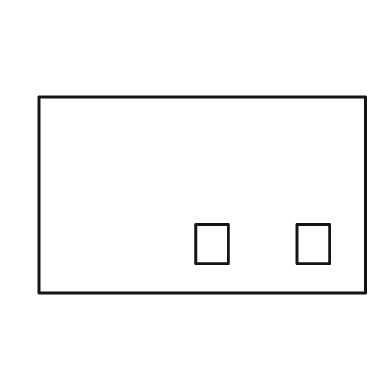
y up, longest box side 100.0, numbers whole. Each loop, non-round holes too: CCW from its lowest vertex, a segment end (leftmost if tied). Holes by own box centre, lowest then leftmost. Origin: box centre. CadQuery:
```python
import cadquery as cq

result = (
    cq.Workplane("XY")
    .moveTo(-50.0, -30.0)
    .lineTo(50.0, -30.0)
    .lineTo(50.0, 30.0)
    .lineTo(-50.0, 30.0)
    .close()
    .moveTo(-2.0, -21.0)
    .lineTo(8.0, -21.0)
    .lineTo(8.0, -9.0)
    .lineTo(-2.0, -9.0)
    .close()
    .moveTo(29.0, -21.0)
    .lineTo(39.0, -21.0)
    .lineTo(39.0, -9.0)
    .lineTo(29.0, -9.0)
    .close()
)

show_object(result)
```